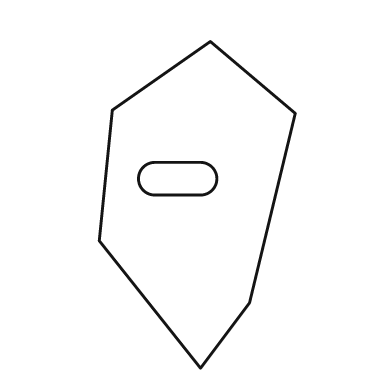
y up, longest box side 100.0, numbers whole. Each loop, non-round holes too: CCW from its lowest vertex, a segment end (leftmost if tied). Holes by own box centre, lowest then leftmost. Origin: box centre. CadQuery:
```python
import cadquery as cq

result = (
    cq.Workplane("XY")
    .moveTo(1.0, -50.0)
    .lineTo(16.0, -30.0)
    .lineTo(30.0, 28.0)
    .lineTo(4.0, 50.0)
    .lineTo(-26.0, 29.0)
    .lineTo(-30.0, -11.0)
    .close()
    .moveTo(-13.0, 3.0)
    .lineTo(1.0, 3.0)
    .threePointArc((6.0, 8.0), (1.0, 13.0))
    .lineTo(-13.0, 13.0)
    .threePointArc((-18.0, 8.0), (-13.0, 3.0))
    .close()
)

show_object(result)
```